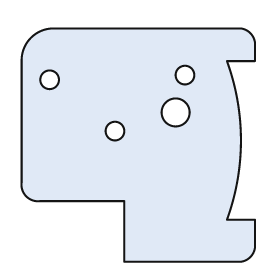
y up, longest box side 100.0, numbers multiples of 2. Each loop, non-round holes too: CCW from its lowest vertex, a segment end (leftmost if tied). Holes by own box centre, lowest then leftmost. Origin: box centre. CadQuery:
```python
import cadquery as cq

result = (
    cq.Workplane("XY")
    .moveTo(-6.0, -50.0)
    .lineTo(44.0, -50.0)
    .threePointArc((48.0, -48.0), (50.0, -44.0))
    .lineTo(50.0, -32.0)
    .lineTo(38.0, -32.0)
    .threePointArc((44.0, 2.0), (38.0, 36.0))
    .lineTo(50.0, 36.0)
    .lineTo(50.0, 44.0)
    .threePointArc((48.0, 48.0), (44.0, 50.0))
    .lineTo(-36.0, 50.0)
    .threePointArc((-46.0, 46.0), (-50.0, 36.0))
    .lineTo(-50.0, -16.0)
    .threePointArc((-48.0, -22.0), (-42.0, -24.0))
    .lineTo(-6.0, -24.0)
    .close()
    .moveTo(-10.0, 6.0)
    .circle(4.0)
    .moveTo(16.0, 14.0)
    .circle(6.0)
    .moveTo(-38.0, 28.0)
    .circle(4.0)
    .moveTo(20.0, 30.0)
    .circle(4.0)
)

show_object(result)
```